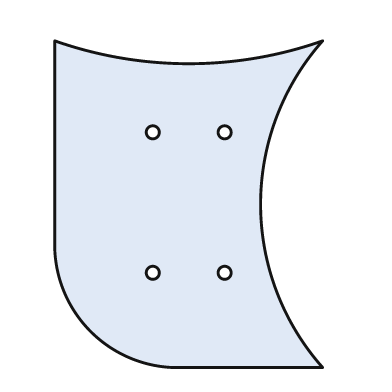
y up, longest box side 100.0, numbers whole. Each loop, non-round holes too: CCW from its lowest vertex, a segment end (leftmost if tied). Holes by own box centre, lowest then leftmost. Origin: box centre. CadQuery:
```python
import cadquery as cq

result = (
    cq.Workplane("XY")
    .moveTo(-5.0, -50.0)
    .lineTo(41.0, -50.0)
    .threePointArc((22.0, 0.0), (41.0, 50.0))
    .threePointArc((0.0, 43.0), (-41.0, 50.0))
    .lineTo(-41.0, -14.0)
    .threePointArc((-30.0, -39.0), (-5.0, -50.0))
    .close()
    .moveTo(-11.0, -21.0)
    .circle(2.0)
    .moveTo(11.0, -21.0)
    .circle(2.0)
    .moveTo(-11.0, 22.0)
    .circle(2.0)
    .moveTo(11.0, 22.0)
    .circle(2.0)
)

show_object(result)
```